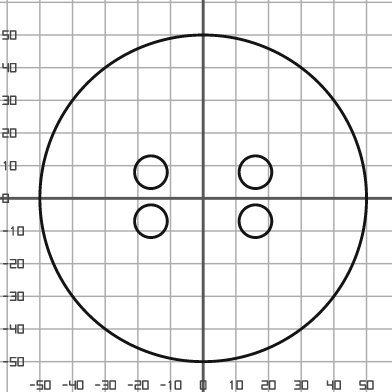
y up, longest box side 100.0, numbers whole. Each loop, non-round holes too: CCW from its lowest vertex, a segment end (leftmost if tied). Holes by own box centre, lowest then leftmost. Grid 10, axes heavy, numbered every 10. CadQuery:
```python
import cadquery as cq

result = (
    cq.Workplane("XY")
    .moveTo(0.0, 0.0)
    .circle(50.0)
    .moveTo(-16.0, -7.0)
    .circle(5.0)
    .moveTo(16.0, -7.0)
    .circle(5.0)
    .moveTo(-16.0, 8.0)
    .circle(5.0)
    .moveTo(16.0, 8.0)
    .circle(5.0)
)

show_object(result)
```